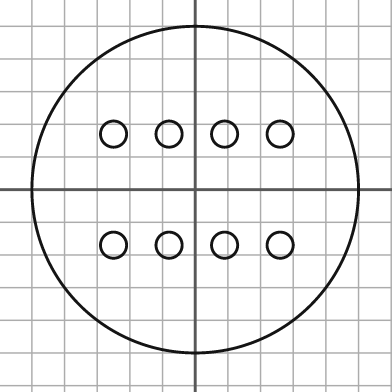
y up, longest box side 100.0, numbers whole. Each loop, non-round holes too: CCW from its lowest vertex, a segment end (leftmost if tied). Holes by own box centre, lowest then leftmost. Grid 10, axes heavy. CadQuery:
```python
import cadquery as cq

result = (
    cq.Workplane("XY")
    .moveTo(0.0, 0.0)
    .circle(50.0)
    .moveTo(-25.0, -17.0)
    .circle(4.0)
    .moveTo(-8.0, -17.0)
    .circle(4.0)
    .moveTo(9.0, -17.0)
    .circle(4.0)
    .moveTo(26.0, -17.0)
    .circle(4.0)
    .moveTo(-25.0, 17.0)
    .circle(4.0)
    .moveTo(-8.0, 17.0)
    .circle(4.0)
    .moveTo(9.0, 17.0)
    .circle(4.0)
    .moveTo(26.0, 17.0)
    .circle(4.0)
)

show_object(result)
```